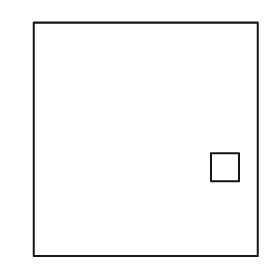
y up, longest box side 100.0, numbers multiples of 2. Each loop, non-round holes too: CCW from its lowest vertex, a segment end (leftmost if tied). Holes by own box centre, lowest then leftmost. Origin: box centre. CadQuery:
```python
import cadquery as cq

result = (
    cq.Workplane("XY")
    .moveTo(-48.0, -50.0)
    .lineTo(48.0, -50.0)
    .lineTo(48.0, 50.0)
    .lineTo(-48.0, 50.0)
    .close()
    .moveTo(28.0, -18.0)
    .lineTo(40.0, -18.0)
    .lineTo(40.0, -6.0)
    .lineTo(28.0, -6.0)
    .close()
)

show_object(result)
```